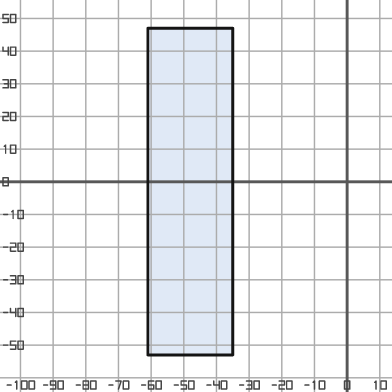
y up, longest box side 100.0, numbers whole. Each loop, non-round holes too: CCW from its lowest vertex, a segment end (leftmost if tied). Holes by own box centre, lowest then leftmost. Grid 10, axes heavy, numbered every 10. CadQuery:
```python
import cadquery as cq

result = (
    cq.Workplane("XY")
    .moveTo(-61.0, -53.0)
    .lineTo(-35.0, -53.0)
    .lineTo(-35.0, 47.0)
    .lineTo(-61.0, 47.0)
    .close()
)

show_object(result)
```